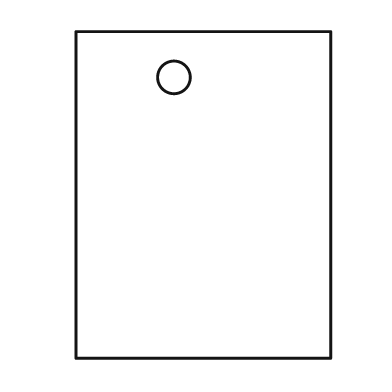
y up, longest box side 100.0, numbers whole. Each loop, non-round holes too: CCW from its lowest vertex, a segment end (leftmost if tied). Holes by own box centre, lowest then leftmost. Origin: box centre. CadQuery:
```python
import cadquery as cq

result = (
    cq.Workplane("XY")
    .moveTo(-39.0, -50.0)
    .lineTo(39.0, -50.0)
    .lineTo(39.0, 50.0)
    .lineTo(-39.0, 50.0)
    .close()
    .moveTo(-9.0, 36.0)
    .circle(5.0)
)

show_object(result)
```